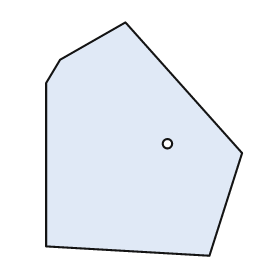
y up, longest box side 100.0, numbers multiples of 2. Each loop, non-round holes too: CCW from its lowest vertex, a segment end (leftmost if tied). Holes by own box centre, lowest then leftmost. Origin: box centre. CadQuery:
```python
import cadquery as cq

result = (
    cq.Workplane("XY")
    .moveTo(28.0, -50.0)
    .lineTo(42.0, -6.0)
    .lineTo(-8.0, 50.0)
    .lineTo(-36.0, 34.0)
    .lineTo(-42.0, 24.0)
    .lineTo(-42.0, -46.0)
    .close()
    .moveTo(10.0, -2.0)
    .circle(2.0)
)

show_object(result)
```